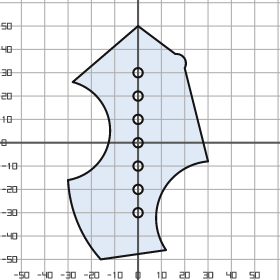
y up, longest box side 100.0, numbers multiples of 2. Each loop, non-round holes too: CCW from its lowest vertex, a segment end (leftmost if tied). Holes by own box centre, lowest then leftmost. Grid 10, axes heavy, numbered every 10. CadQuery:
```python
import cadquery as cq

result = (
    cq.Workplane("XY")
    .moveTo(-16.0, -50.0)
    .lineTo(12.0, -46.0)
    .threePointArc((10.0, -22.0), (30.0, -8.0))
    .lineTo(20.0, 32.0)
    .threePointArc((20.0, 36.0), (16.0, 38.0))
    .lineTo(0.0, 50.0)
    .lineTo(-28.0, 26.0)
    .threePointArc((-12.0, 4.0), (-30.0, -16.0))
    .threePointArc((-26.0, -34.0), (-16.0, -50.0))
    .close()
    .moveTo(0.0, -30.0)
    .circle(2.0)
    .moveTo(0.0, -20.0)
    .circle(2.0)
    .moveTo(0.0, -10.0)
    .circle(2.0)
    .moveTo(0.0, 0.0)
    .circle(2.0)
    .moveTo(0.0, 10.0)
    .circle(2.0)
    .moveTo(0.0, 20.0)
    .circle(2.0)
    .moveTo(0.0, 30.0)
    .circle(2.0)
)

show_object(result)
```